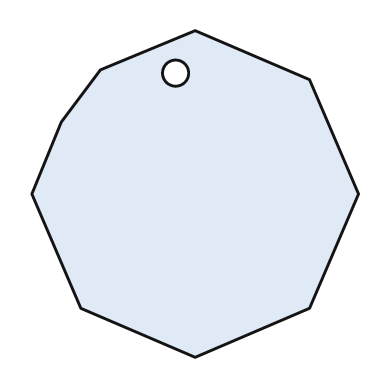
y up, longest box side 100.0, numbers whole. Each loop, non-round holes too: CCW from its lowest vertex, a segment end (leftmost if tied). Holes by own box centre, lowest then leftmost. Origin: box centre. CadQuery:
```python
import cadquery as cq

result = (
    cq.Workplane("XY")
    .moveTo(0.0, -50.0)
    .lineTo(35.0, -35.0)
    .lineTo(50.0, 0.0)
    .lineTo(35.0, 35.0)
    .lineTo(0.0, 50.0)
    .lineTo(-29.0, 38.0)
    .lineTo(-41.0, 22.0)
    .lineTo(-50.0, 0.0)
    .lineTo(-35.0, -35.0)
    .close()
    .moveTo(-6.0, 37.0)
    .circle(4.0)
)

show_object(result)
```